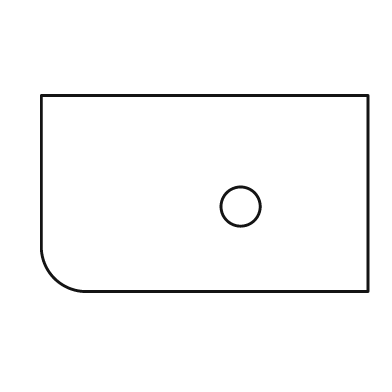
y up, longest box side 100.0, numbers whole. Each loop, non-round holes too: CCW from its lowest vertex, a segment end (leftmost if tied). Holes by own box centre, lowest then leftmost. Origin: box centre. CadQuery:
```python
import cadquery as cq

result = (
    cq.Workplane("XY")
    .moveTo(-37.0, -30.0)
    .lineTo(50.0, -30.0)
    .lineTo(50.0, 30.0)
    .lineTo(-50.0, 30.0)
    .lineTo(-50.0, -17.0)
    .threePointArc((-46.0, -26.0), (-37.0, -30.0))
    .close()
    .moveTo(11.0, -4.0)
    .circle(6.0)
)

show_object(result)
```